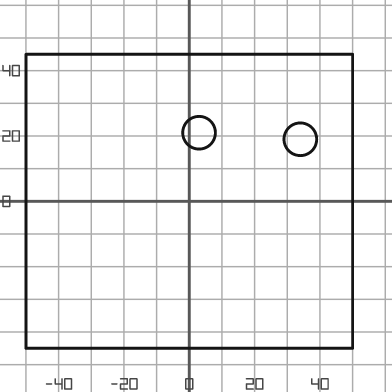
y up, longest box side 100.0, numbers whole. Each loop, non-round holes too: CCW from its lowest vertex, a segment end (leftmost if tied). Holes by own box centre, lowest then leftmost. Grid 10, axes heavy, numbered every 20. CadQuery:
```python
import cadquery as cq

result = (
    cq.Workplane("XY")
    .moveTo(-50.0, -45.0)
    .lineTo(50.0, -45.0)
    .lineTo(50.0, 45.0)
    .lineTo(-50.0, 45.0)
    .close()
    .moveTo(34.0, 19.0)
    .circle(5.0)
    .moveTo(3.0, 21.0)
    .circle(5.0)
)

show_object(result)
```